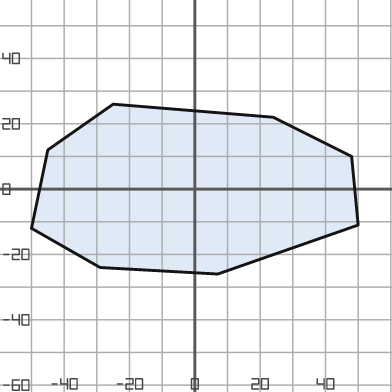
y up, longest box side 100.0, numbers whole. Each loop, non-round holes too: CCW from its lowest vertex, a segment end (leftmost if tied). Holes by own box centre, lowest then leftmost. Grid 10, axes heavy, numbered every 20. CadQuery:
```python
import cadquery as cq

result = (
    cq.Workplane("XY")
    .moveTo(7.0, -26.0)
    .lineTo(50.0, -11.0)
    .lineTo(48.0, 10.0)
    .lineTo(24.0, 22.0)
    .lineTo(-25.0, 26.0)
    .lineTo(-45.0, 12.0)
    .lineTo(-50.0, -12.0)
    .lineTo(-29.0, -24.0)
    .close()
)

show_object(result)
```